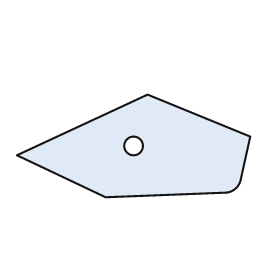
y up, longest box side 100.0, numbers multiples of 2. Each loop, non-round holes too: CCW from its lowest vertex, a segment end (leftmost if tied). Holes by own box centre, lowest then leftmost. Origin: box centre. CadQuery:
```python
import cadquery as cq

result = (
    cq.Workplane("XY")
    .moveTo(-12.0, -22.0)
    .lineTo(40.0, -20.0)
    .threePointArc((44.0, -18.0), (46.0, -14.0))
    .lineTo(50.0, 4.0)
    .lineTo(6.0, 22.0)
    .lineTo(-50.0, -4.0)
    .close()
    .moveTo(0.0, 0.0)
    .circle(4.0)
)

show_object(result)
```